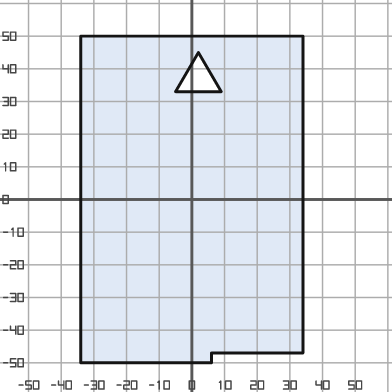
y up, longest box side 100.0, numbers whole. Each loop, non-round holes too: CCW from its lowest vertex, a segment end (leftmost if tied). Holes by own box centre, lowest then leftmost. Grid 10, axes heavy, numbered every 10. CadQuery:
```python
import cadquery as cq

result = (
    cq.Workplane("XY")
    .moveTo(-34.0, -50.0)
    .lineTo(6.0, -50.0)
    .lineTo(6.0, -47.0)
    .lineTo(34.0, -47.0)
    .lineTo(34.0, 50.0)
    .lineTo(-34.0, 50.0)
    .close()
    .moveTo(-5.0, 33.0)
    .lineTo(9.0, 33.0)
    .lineTo(2.0, 45.0)
    .close()
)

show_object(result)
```